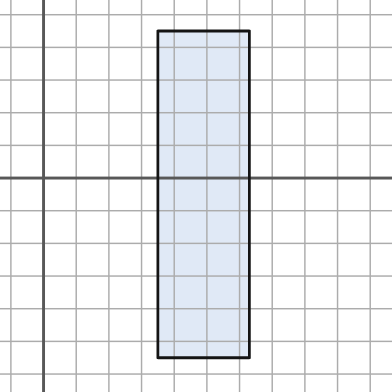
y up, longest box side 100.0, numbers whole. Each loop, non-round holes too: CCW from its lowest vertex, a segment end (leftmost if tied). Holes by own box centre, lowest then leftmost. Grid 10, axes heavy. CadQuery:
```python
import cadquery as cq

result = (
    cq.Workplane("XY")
    .moveTo(35.0, -55.0)
    .lineTo(63.0, -55.0)
    .lineTo(63.0, 45.0)
    .lineTo(35.0, 45.0)
    .close()
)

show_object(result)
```